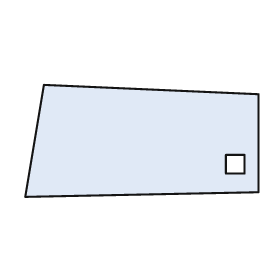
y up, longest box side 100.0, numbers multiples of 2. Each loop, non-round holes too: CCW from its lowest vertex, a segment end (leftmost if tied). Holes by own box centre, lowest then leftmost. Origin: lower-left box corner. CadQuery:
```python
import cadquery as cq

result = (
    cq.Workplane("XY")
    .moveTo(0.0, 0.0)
    .lineTo(100.0, 2.0)
    .lineTo(100.0, 44.0)
    .lineTo(8.0, 48.0)
    .close()
    .moveTo(86.0, 10.0)
    .lineTo(94.0, 10.0)
    .lineTo(94.0, 18.0)
    .lineTo(86.0, 18.0)
    .close()
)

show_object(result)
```